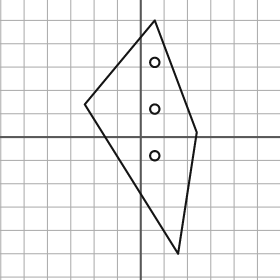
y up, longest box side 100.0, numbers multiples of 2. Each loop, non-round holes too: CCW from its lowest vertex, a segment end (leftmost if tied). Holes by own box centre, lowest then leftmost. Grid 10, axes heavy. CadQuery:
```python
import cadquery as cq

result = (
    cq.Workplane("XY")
    .moveTo(16.0, -50.0)
    .lineTo(24.0, 2.0)
    .lineTo(6.0, 50.0)
    .lineTo(-24.0, 14.0)
    .close()
    .moveTo(6.0, -8.0)
    .circle(2.0)
    .moveTo(6.0, 12.0)
    .circle(2.0)
    .moveTo(6.0, 32.0)
    .circle(2.0)
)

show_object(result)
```